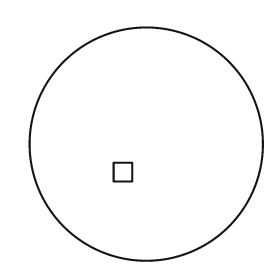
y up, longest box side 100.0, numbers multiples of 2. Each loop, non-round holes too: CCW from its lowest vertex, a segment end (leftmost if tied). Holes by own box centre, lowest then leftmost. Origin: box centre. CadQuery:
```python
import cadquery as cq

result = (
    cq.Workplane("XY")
    .moveTo(0.0, 0.0)
    .circle(50.0)
    .moveTo(-14.0, -16.0)
    .lineTo(-6.0, -16.0)
    .lineTo(-6.0, -8.0)
    .lineTo(-14.0, -8.0)
    .close()
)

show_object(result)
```